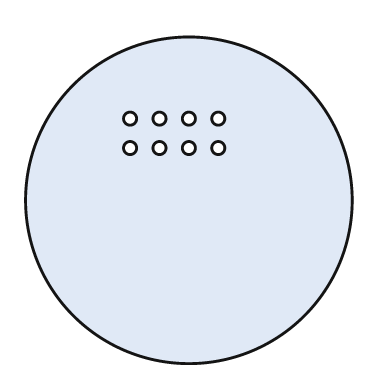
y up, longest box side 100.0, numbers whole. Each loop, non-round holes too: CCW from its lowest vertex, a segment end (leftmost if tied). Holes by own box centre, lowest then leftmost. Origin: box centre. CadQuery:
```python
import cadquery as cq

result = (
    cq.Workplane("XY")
    .moveTo(0.0, 0.0)
    .circle(50.0)
    .moveTo(-18.0, 16.0)
    .circle(2.0)
    .moveTo(-9.0, 16.0)
    .circle(2.0)
    .moveTo(0.0, 16.0)
    .circle(2.0)
    .moveTo(9.0, 16.0)
    .circle(2.0)
    .moveTo(-18.0, 25.0)
    .circle(2.0)
    .moveTo(-9.0, 25.0)
    .circle(2.0)
    .moveTo(0.0, 25.0)
    .circle(2.0)
    .moveTo(9.0, 25.0)
    .circle(2.0)
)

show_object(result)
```